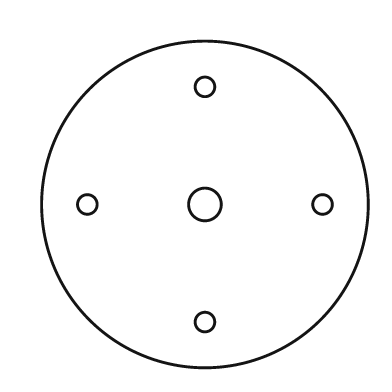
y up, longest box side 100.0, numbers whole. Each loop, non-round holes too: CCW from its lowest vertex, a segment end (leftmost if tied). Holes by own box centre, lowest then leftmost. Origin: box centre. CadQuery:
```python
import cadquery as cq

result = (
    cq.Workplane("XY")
    .moveTo(0.0, 0.0)
    .circle(50.0)
    .moveTo(0.0, -36.0)
    .circle(3.0)
    .moveTo(-36.0, 0.0)
    .circle(3.0)
    .moveTo(0.0, 0.0)
    .circle(5.0)
    .moveTo(36.0, 0.0)
    .circle(3.0)
    .moveTo(0.0, 36.0)
    .circle(3.0)
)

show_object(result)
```